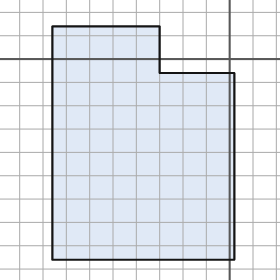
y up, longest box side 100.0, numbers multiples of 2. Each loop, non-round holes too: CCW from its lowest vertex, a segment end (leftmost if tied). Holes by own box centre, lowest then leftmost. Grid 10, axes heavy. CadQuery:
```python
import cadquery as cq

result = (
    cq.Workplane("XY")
    .moveTo(-76.0, -86.0)
    .lineTo(2.0, -86.0)
    .lineTo(2.0, -6.0)
    .lineTo(-30.0, -6.0)
    .lineTo(-30.0, 14.0)
    .lineTo(-76.0, 14.0)
    .close()
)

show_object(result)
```